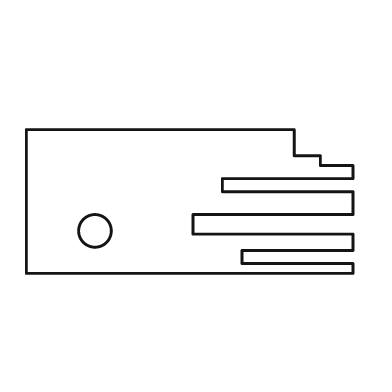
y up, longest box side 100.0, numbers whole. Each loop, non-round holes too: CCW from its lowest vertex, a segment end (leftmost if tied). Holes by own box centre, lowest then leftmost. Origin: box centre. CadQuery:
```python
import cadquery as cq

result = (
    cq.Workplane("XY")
    .moveTo(-50.0, -22.0)
    .lineTo(50.0, -22.0)
    .lineTo(50.0, -19.0)
    .lineTo(16.0, -19.0)
    .lineTo(16.0, -15.0)
    .lineTo(50.0, -15.0)
    .lineTo(50.0, -10.0)
    .lineTo(1.0, -10.0)
    .lineTo(1.0, -4.0)
    .lineTo(50.0, -4.0)
    .lineTo(50.0, 3.0)
    .lineTo(10.0, 3.0)
    .lineTo(10.0, 7.0)
    .lineTo(50.0, 7.0)
    .lineTo(50.0, 11.0)
    .lineTo(40.0, 11.0)
    .lineTo(40.0, 14.0)
    .lineTo(32.0, 14.0)
    .lineTo(32.0, 22.0)
    .lineTo(-50.0, 22.0)
    .close()
    .moveTo(-29.0, -9.0)
    .circle(5.0)
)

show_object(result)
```